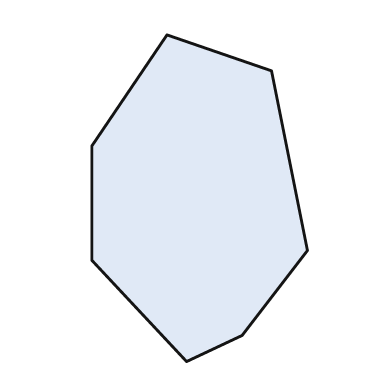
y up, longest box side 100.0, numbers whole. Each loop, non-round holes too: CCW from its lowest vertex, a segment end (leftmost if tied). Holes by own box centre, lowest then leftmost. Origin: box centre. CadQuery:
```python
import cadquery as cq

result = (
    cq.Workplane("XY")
    .moveTo(-4.0, -50.0)
    .lineTo(13.0, -42.0)
    .lineTo(33.0, -16.0)
    .lineTo(22.0, 39.0)
    .lineTo(-10.0, 50.0)
    .lineTo(-33.0, 16.0)
    .lineTo(-33.0, -19.0)
    .close()
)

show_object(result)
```